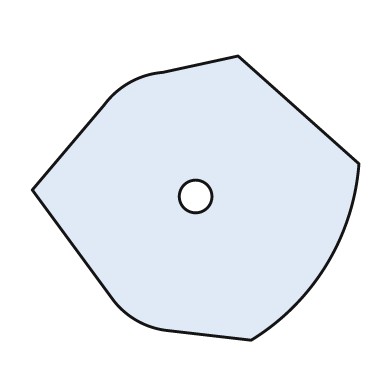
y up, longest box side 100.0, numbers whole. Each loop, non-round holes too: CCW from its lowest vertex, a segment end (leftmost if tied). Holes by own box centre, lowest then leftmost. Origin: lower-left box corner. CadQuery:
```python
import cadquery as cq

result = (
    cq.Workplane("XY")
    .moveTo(67.0, 0.0)
    .threePointArc((90.0, 23.0), (100.0, 54.0))
    .lineTo(63.0, 87.0)
    .lineTo(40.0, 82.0)
    .threePointArc((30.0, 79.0), (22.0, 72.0))
    .lineTo(0.0, 46.0)
    .lineTo(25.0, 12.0)
    .threePointArc((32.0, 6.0), (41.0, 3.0))
    .close()
    .moveTo(50.0, 44.0)
    .circle(5.0)
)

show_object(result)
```